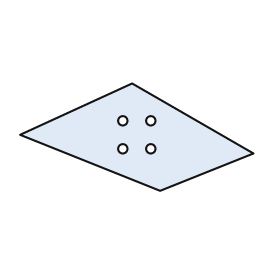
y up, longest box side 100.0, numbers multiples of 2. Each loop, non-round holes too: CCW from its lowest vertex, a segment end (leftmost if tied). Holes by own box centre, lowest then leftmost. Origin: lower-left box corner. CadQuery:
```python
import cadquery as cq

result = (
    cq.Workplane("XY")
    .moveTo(60.0, 0.0)
    .lineTo(100.0, 16.0)
    .lineTo(48.0, 46.0)
    .lineTo(0.0, 24.0)
    .close()
    .moveTo(44.0, 18.0)
    .circle(2.0)
    .moveTo(56.0, 18.0)
    .circle(2.0)
    .moveTo(44.0, 30.0)
    .circle(2.0)
    .moveTo(56.0, 30.0)
    .circle(2.0)
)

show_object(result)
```